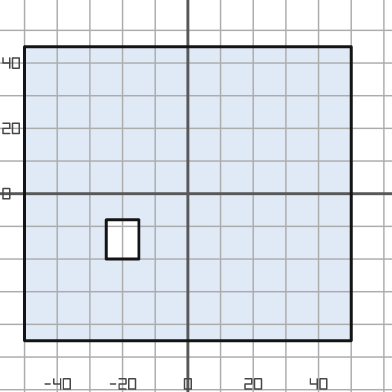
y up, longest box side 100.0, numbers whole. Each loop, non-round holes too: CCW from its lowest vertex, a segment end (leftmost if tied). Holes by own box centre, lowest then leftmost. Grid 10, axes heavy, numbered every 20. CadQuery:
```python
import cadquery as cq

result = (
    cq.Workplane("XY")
    .moveTo(-50.0, -45.0)
    .lineTo(50.0, -45.0)
    .lineTo(50.0, 45.0)
    .lineTo(-50.0, 45.0)
    .close()
    .moveTo(-25.0, -20.0)
    .lineTo(-15.0, -20.0)
    .lineTo(-15.0, -8.0)
    .lineTo(-25.0, -8.0)
    .close()
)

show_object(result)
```